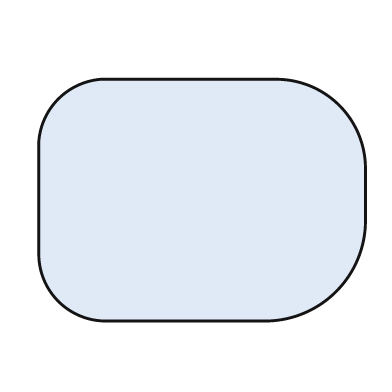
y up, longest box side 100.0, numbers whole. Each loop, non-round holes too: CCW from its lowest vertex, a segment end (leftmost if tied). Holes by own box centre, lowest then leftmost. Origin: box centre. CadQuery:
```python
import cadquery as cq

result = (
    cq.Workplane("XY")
    .moveTo(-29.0, -37.0)
    .lineTo(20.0, -37.0)
    .threePointArc((41.0, -28.0), (50.0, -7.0))
    .lineTo(50.0, 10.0)
    .threePointArc((42.0, 29.0), (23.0, 37.0))
    .lineTo(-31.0, 37.0)
    .threePointArc((-44.0, 31.0), (-50.0, 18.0))
    .lineTo(-50.0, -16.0)
    .threePointArc((-44.0, -31.0), (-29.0, -37.0))
    .close()
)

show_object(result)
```